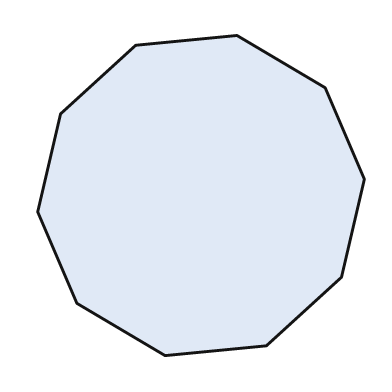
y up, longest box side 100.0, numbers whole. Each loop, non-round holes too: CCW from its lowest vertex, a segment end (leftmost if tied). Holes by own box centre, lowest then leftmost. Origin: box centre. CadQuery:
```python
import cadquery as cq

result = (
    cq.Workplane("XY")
    .moveTo(-11.0, -49.0)
    .lineTo(20.0, -46.0)
    .lineTo(43.0, -25.0)
    .lineTo(50.0, 5.0)
    .lineTo(38.0, 33.0)
    .lineTo(11.0, 49.0)
    .lineTo(-20.0, 46.0)
    .lineTo(-43.0, 25.0)
    .lineTo(-50.0, -5.0)
    .lineTo(-38.0, -33.0)
    .close()
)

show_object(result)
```